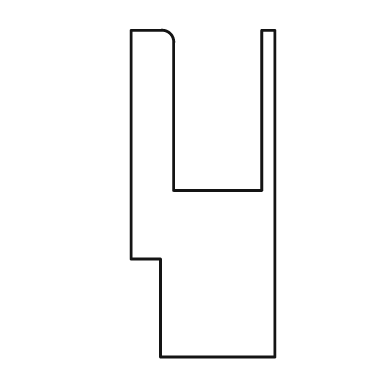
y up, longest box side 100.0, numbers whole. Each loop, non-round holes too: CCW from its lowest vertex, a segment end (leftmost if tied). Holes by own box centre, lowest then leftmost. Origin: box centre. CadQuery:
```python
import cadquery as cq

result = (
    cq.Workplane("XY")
    .moveTo(-13.0, -50.0)
    .lineTo(22.0, -50.0)
    .lineTo(22.0, 50.0)
    .lineTo(18.0, 50.0)
    .lineTo(18.0, 1.0)
    .lineTo(-9.0, 1.0)
    .lineTo(-9.0, 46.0)
    .threePointArc((-10.0, 49.0), (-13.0, 50.0))
    .lineTo(-22.0, 50.0)
    .lineTo(-22.0, -20.0)
    .lineTo(-13.0, -20.0)
    .close()
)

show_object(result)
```